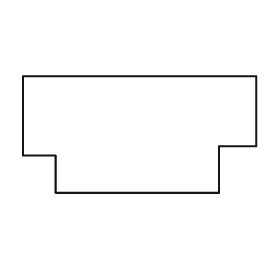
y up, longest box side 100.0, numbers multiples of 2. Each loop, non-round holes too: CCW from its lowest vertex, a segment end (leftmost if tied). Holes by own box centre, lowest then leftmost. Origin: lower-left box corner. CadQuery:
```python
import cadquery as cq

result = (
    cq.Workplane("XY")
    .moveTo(14.0, 0.0)
    .lineTo(84.0, 0.0)
    .lineTo(84.0, 20.0)
    .lineTo(100.0, 20.0)
    .lineTo(100.0, 50.0)
    .lineTo(0.0, 50.0)
    .lineTo(0.0, 16.0)
    .lineTo(14.0, 16.0)
    .close()
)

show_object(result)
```